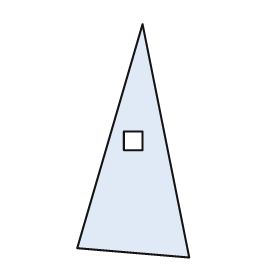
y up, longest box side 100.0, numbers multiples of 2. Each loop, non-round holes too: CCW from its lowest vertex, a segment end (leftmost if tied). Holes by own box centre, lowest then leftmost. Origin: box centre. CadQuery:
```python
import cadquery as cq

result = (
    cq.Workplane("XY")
    .moveTo(24.0, -50.0)
    .lineTo(4.0, 50.0)
    .lineTo(-24.0, -46.0)
    .close()
    .moveTo(-4.0, -4.0)
    .lineTo(4.0, -4.0)
    .lineTo(4.0, 4.0)
    .lineTo(-4.0, 4.0)
    .close()
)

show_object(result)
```